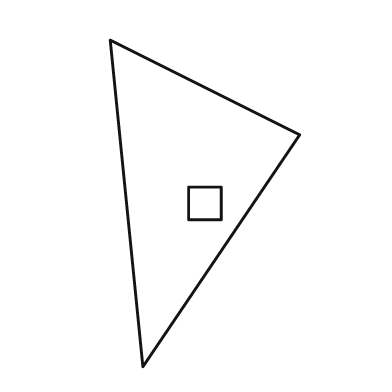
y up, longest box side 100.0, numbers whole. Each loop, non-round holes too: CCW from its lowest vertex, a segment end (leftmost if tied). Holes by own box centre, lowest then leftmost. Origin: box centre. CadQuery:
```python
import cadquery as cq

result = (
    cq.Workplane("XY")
    .moveTo(-19.0, -50.0)
    .lineTo(29.0, 21.0)
    .lineTo(-29.0, 50.0)
    .close()
    .moveTo(-5.0, -5.0)
    .lineTo(5.0, -5.0)
    .lineTo(5.0, 5.0)
    .lineTo(-5.0, 5.0)
    .close()
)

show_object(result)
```